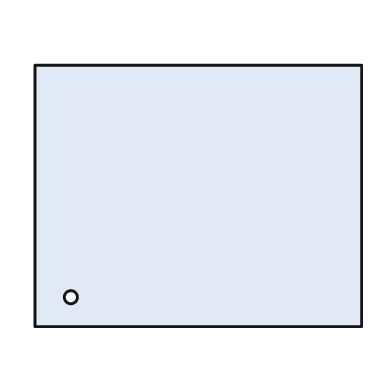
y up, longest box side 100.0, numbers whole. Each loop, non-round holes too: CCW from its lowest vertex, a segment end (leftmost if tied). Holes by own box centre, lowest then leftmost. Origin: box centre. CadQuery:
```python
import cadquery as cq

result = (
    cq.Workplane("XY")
    .moveTo(-50.0, -40.0)
    .lineTo(50.0, -40.0)
    .lineTo(50.0, 40.0)
    .lineTo(-50.0, 40.0)
    .close()
    .moveTo(-39.0, -31.0)
    .circle(2.0)
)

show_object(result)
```